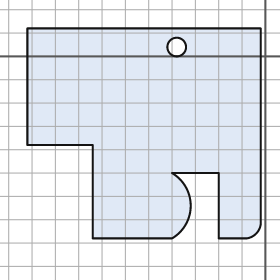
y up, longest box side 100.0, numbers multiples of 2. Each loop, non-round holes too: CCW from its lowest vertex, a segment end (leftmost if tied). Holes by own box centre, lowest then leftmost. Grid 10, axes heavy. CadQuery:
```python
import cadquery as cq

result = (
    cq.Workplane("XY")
    .moveTo(-74.0, -78.0)
    .lineTo(-40.0, -78.0)
    .threePointArc((-32.0, -64.0), (-40.0, -50.0))
    .lineTo(-20.0, -50.0)
    .lineTo(-20.0, -78.0)
    .lineTo(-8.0, -78.0)
    .threePointArc((-4.0, -76.0), (-2.0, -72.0))
    .lineTo(-2.0, 12.0)
    .lineTo(-102.0, 12.0)
    .lineTo(-102.0, -38.0)
    .lineTo(-74.0, -38.0)
    .close()
    .moveTo(-38.0, 4.0)
    .circle(4.0)
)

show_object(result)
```